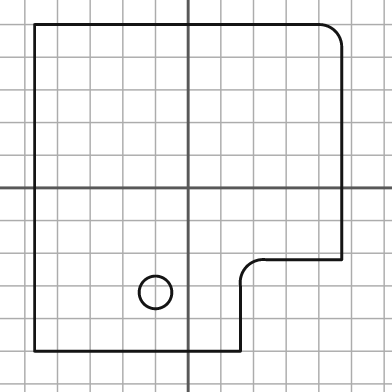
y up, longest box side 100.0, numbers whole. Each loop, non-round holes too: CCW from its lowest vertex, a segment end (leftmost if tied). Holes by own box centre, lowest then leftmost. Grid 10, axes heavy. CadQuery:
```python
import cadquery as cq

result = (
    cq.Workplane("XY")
    .moveTo(-47.0, -50.0)
    .lineTo(16.0, -50.0)
    .lineTo(16.0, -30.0)
    .threePointArc((18.0, -24.0), (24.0, -22.0))
    .lineTo(47.0, -22.0)
    .lineTo(47.0, 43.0)
    .threePointArc((45.0, 48.0), (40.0, 50.0))
    .lineTo(-47.0, 50.0)
    .close()
    .moveTo(-10.0, -32.0)
    .circle(5.0)
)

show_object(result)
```